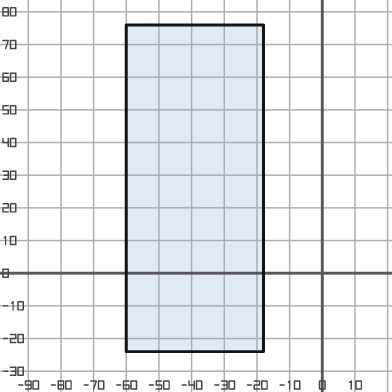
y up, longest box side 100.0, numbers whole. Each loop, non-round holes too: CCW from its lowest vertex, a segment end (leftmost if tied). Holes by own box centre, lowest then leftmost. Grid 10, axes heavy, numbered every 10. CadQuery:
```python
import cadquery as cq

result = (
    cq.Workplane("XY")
    .moveTo(-60.0, -24.0)
    .lineTo(-18.0, -24.0)
    .lineTo(-18.0, 76.0)
    .lineTo(-60.0, 76.0)
    .close()
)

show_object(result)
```